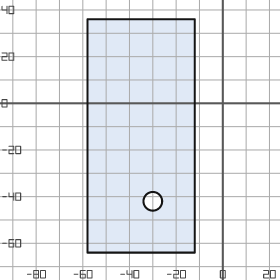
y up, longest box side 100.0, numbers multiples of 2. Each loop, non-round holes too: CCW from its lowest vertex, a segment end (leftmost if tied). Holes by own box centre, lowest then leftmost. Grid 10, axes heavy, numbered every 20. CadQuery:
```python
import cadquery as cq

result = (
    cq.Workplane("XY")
    .moveTo(-58.0, -64.0)
    .lineTo(-12.0, -64.0)
    .lineTo(-12.0, 36.0)
    .lineTo(-58.0, 36.0)
    .close()
    .moveTo(-30.0, -42.0)
    .circle(4.0)
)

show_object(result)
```